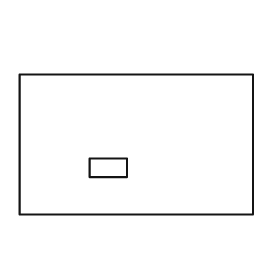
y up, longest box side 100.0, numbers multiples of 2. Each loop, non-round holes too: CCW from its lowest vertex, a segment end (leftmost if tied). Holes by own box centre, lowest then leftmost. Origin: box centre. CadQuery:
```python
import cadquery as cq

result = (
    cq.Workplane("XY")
    .moveTo(-50.0, -30.0)
    .lineTo(50.0, -30.0)
    .lineTo(50.0, 30.0)
    .lineTo(-50.0, 30.0)
    .close()
    .moveTo(-20.0, -14.0)
    .lineTo(-4.0, -14.0)
    .lineTo(-4.0, -6.0)
    .lineTo(-20.0, -6.0)
    .close()
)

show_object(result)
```